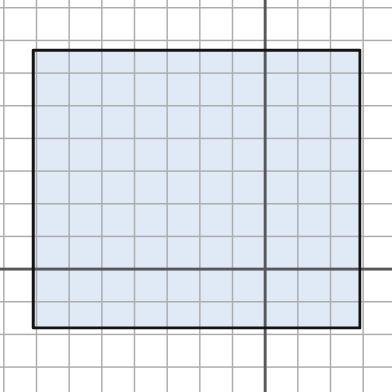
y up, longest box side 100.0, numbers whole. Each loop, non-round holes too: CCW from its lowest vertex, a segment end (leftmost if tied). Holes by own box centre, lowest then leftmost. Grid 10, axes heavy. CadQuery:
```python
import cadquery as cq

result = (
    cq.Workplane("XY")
    .moveTo(-71.0, -18.0)
    .lineTo(29.0, -18.0)
    .lineTo(29.0, 67.0)
    .lineTo(-71.0, 67.0)
    .close()
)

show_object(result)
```